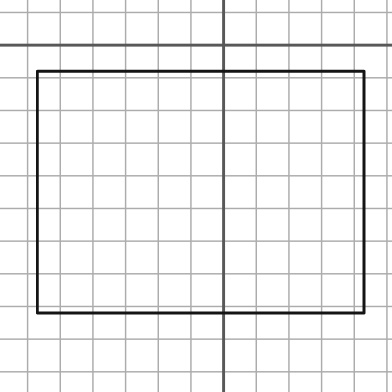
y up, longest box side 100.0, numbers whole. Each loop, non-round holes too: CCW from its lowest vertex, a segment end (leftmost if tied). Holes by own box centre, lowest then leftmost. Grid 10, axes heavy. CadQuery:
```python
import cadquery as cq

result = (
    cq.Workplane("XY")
    .moveTo(-57.0, -82.0)
    .lineTo(43.0, -82.0)
    .lineTo(43.0, -8.0)
    .lineTo(-57.0, -8.0)
    .close()
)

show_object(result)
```